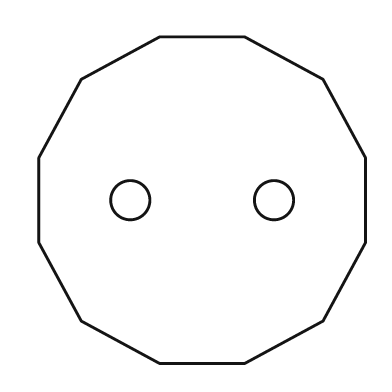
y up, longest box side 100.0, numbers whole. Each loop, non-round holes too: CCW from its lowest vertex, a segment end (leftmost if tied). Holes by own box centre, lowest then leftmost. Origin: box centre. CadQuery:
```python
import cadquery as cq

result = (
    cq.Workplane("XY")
    .moveTo(-13.0, -50.0)
    .lineTo(13.0, -50.0)
    .lineTo(37.0, -37.0)
    .lineTo(50.0, -13.0)
    .lineTo(50.0, 13.0)
    .lineTo(37.0, 37.0)
    .lineTo(13.0, 50.0)
    .lineTo(-13.0, 50.0)
    .lineTo(-37.0, 37.0)
    .lineTo(-50.0, 13.0)
    .lineTo(-50.0, -13.0)
    .lineTo(-37.0, -37.0)
    .close()
    .moveTo(-22.0, 0.0)
    .circle(6.0)
    .moveTo(22.0, 0.0)
    .circle(6.0)
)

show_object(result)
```